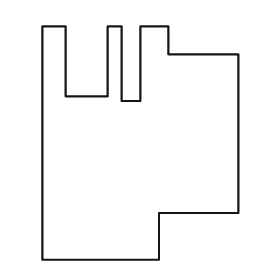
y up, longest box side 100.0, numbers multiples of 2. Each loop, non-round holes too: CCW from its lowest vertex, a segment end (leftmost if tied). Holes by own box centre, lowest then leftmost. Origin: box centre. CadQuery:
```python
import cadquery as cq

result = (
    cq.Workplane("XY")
    .moveTo(-42.0, -50.0)
    .lineTo(8.0, -50.0)
    .lineTo(8.0, -30.0)
    .lineTo(42.0, -30.0)
    .lineTo(42.0, 38.0)
    .lineTo(12.0, 38.0)
    .lineTo(12.0, 50.0)
    .lineTo(0.0, 50.0)
    .lineTo(0.0, 18.0)
    .lineTo(-8.0, 18.0)
    .lineTo(-8.0, 50.0)
    .lineTo(-14.0, 50.0)
    .lineTo(-14.0, 20.0)
    .lineTo(-32.0, 20.0)
    .lineTo(-32.0, 50.0)
    .lineTo(-42.0, 50.0)
    .close()
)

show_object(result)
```